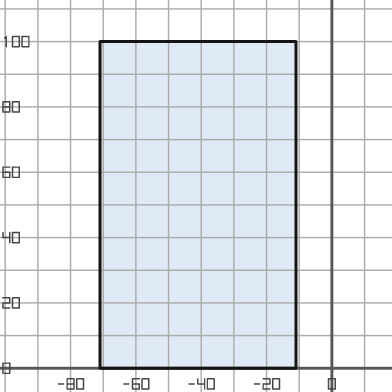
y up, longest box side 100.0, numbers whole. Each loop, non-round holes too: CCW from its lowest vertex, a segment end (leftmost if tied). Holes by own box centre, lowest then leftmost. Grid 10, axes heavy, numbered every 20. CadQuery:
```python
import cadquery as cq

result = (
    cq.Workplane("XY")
    .moveTo(-71.0, 0.0)
    .lineTo(-11.0, 0.0)
    .lineTo(-11.0, 100.0)
    .lineTo(-71.0, 100.0)
    .close()
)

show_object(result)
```